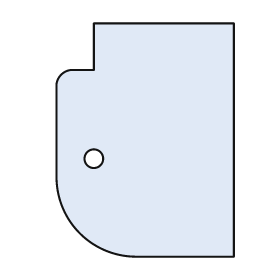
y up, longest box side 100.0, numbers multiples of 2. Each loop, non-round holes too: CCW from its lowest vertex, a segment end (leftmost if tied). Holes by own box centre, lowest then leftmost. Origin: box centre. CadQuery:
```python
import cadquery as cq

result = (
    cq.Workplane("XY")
    .moveTo(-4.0, -50.0)
    .lineTo(38.0, -50.0)
    .lineTo(38.0, 50.0)
    .lineTo(-22.0, 50.0)
    .lineTo(-22.0, 30.0)
    .lineTo(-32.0, 30.0)
    .threePointArc((-36.0, 28.0), (-38.0, 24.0))
    .lineTo(-38.0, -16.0)
    .threePointArc((-28.0, -40.0), (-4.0, -50.0))
    .close()
    .moveTo(-22.0, -8.0)
    .circle(4.0)
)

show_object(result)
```